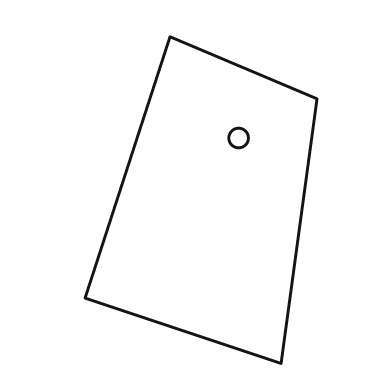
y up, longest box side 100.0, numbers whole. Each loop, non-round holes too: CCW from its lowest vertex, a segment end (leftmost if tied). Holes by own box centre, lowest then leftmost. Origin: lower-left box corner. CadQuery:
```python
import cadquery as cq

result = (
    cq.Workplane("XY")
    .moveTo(60.0, 0.0)
    .lineTo(71.0, 81.0)
    .lineTo(26.0, 100.0)
    .lineTo(0.0, 20.0)
    .close()
    .moveTo(47.0, 69.0)
    .circle(3.0)
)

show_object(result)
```